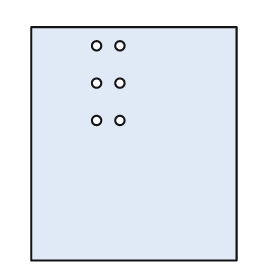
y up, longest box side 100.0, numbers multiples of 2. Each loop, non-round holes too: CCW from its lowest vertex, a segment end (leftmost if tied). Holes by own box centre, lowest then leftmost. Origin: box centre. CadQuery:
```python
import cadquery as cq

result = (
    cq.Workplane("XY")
    .moveTo(-44.0, -50.0)
    .lineTo(44.0, -50.0)
    .lineTo(44.0, 50.0)
    .lineTo(-44.0, 50.0)
    .close()
    .moveTo(-16.0, 10.0)
    .circle(2.0)
    .moveTo(-6.0, 10.0)
    .circle(2.0)
    .moveTo(-16.0, 26.0)
    .circle(2.0)
    .moveTo(-6.0, 26.0)
    .circle(2.0)
    .moveTo(-16.0, 42.0)
    .circle(2.0)
    .moveTo(-6.0, 42.0)
    .circle(2.0)
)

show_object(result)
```